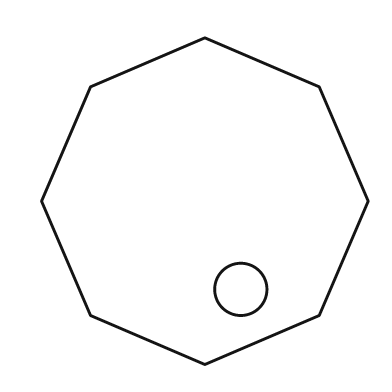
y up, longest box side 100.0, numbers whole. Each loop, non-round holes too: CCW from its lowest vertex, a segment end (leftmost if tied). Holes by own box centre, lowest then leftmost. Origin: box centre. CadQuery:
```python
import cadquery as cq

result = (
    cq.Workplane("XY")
    .moveTo(0.0, -50.0)
    .lineTo(35.0, -35.0)
    .lineTo(50.0, 0.0)
    .lineTo(35.0, 35.0)
    .lineTo(0.0, 50.0)
    .lineTo(-35.0, 35.0)
    .lineTo(-50.0, 0.0)
    .lineTo(-35.0, -35.0)
    .close()
    .moveTo(11.0, -27.0)
    .circle(8.0)
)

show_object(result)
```